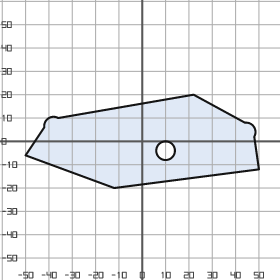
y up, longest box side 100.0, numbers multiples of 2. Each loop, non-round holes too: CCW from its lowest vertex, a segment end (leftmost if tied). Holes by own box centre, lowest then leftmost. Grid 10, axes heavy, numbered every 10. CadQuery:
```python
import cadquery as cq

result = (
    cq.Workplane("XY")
    .moveTo(-12.0, -20.0)
    .lineTo(50.0, -12.0)
    .lineTo(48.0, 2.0)
    .threePointArc((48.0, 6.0), (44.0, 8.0))
    .lineTo(22.0, 20.0)
    .lineTo(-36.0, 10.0)
    .threePointArc((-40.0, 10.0), (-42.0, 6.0))
    .lineTo(-50.0, -6.0)
    .close()
    .moveTo(10.0, -4.0)
    .circle(4.0)
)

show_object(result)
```